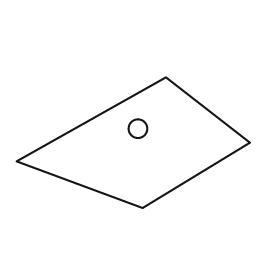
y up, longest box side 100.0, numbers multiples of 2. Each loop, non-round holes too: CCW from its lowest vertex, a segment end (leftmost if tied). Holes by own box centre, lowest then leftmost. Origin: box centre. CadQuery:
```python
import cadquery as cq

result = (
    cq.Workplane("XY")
    .moveTo(4.0, -28.0)
    .lineTo(50.0, 0.0)
    .lineTo(14.0, 28.0)
    .lineTo(-50.0, -8.0)
    .close()
    .moveTo(2.0, 6.0)
    .circle(4.0)
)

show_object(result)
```